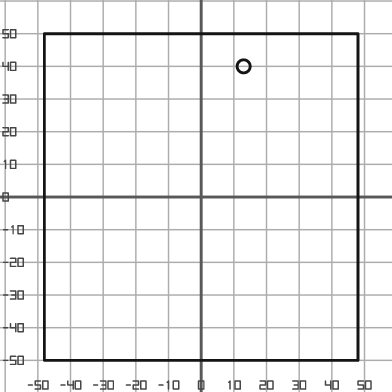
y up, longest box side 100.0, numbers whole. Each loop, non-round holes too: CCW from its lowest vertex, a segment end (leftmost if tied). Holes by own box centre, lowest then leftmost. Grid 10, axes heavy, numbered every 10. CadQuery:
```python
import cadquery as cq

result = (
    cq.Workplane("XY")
    .moveTo(-48.0, -50.0)
    .lineTo(48.0, -50.0)
    .lineTo(48.0, 50.0)
    .lineTo(-48.0, 50.0)
    .close()
    .moveTo(13.0, 40.0)
    .circle(2.0)
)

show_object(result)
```